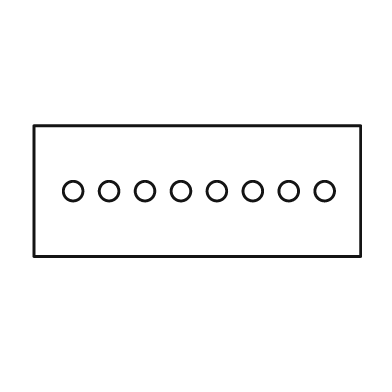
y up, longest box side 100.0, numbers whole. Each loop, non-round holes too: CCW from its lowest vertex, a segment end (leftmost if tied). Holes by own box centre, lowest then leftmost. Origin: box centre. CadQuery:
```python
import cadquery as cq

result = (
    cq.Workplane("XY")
    .moveTo(-50.0, -20.0)
    .lineTo(50.0, -20.0)
    .lineTo(50.0, 20.0)
    .lineTo(-50.0, 20.0)
    .close()
    .moveTo(-38.0, 0.0)
    .circle(3.0)
    .moveTo(-27.0, 0.0)
    .circle(3.0)
    .moveTo(-16.0, 0.0)
    .circle(3.0)
    .moveTo(-5.0, 0.0)
    .circle(3.0)
    .moveTo(6.0, 0.0)
    .circle(3.0)
    .moveTo(17.0, 0.0)
    .circle(3.0)
    .moveTo(28.0, 0.0)
    .circle(3.0)
    .moveTo(39.0, 0.0)
    .circle(3.0)
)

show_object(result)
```